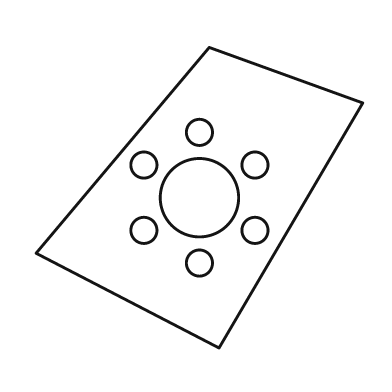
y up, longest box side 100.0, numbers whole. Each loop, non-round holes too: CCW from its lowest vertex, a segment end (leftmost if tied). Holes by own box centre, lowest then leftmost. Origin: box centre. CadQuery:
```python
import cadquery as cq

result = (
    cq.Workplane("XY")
    .moveTo(6.0, -46.0)
    .lineTo(50.0, 29.0)
    .lineTo(3.0, 46.0)
    .lineTo(-50.0, -17.0)
    .close()
    .moveTo(0.0, -20.0)
    .circle(4.0)
    .moveTo(-17.0, -10.0)
    .circle(4.0)
    .moveTo(17.0, -10.0)
    .circle(4.0)
    .moveTo(0.0, 0.0)
    .circle(12.0)
    .moveTo(-17.0, 10.0)
    .circle(4.0)
    .moveTo(17.0, 10.0)
    .circle(4.0)
    .moveTo(0.0, 20.0)
    .circle(4.0)
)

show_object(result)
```